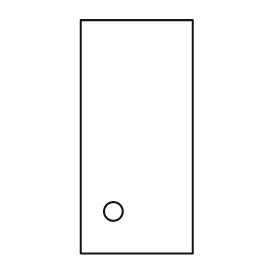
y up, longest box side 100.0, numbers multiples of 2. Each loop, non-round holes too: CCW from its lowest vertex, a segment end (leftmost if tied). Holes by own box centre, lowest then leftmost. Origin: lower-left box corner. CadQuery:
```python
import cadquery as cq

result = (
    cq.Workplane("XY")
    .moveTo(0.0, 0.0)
    .lineTo(48.0, 0.0)
    .lineTo(48.0, 100.0)
    .lineTo(0.0, 100.0)
    .close()
    .moveTo(14.0, 18.0)
    .circle(4.0)
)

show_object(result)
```